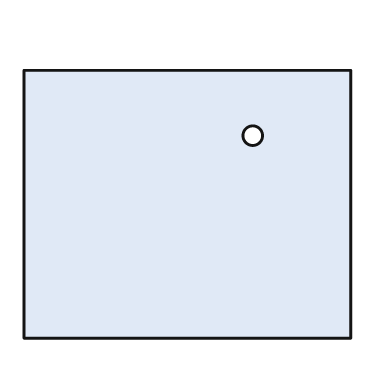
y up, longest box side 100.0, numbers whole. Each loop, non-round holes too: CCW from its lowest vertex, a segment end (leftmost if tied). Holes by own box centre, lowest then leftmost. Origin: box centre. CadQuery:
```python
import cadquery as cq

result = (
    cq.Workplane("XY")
    .moveTo(-50.0, -41.0)
    .lineTo(50.0, -41.0)
    .lineTo(50.0, 41.0)
    .lineTo(-50.0, 41.0)
    .close()
    .moveTo(20.0, 21.0)
    .circle(3.0)
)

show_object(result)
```